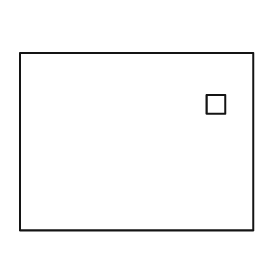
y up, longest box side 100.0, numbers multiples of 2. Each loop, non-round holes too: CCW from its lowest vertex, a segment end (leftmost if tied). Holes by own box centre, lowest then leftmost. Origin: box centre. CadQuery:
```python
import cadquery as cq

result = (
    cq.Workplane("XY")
    .moveTo(-50.0, -38.0)
    .lineTo(50.0, -38.0)
    .lineTo(50.0, 38.0)
    .lineTo(-50.0, 38.0)
    .close()
    .moveTo(30.0, 12.0)
    .lineTo(38.0, 12.0)
    .lineTo(38.0, 20.0)
    .lineTo(30.0, 20.0)
    .close()
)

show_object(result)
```